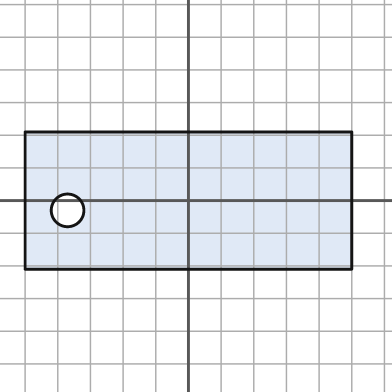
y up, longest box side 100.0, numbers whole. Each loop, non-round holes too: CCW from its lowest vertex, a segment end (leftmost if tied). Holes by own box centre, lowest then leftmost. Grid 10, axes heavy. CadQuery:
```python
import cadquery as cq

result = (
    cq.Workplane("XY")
    .moveTo(-50.0, -21.0)
    .lineTo(50.0, -21.0)
    .lineTo(50.0, 21.0)
    .lineTo(-50.0, 21.0)
    .close()
    .moveTo(-37.0, -3.0)
    .circle(5.0)
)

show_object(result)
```